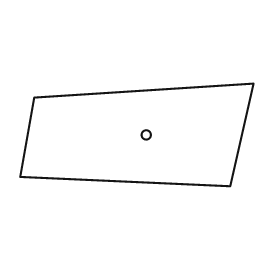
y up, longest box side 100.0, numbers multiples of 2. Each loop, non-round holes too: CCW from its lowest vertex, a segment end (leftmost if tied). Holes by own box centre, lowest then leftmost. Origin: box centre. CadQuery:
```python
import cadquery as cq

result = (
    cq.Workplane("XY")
    .moveTo(40.0, -22.0)
    .lineTo(50.0, 22.0)
    .lineTo(-44.0, 16.0)
    .lineTo(-50.0, -18.0)
    .close()
    .moveTo(4.0, 0.0)
    .circle(2.0)
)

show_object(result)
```